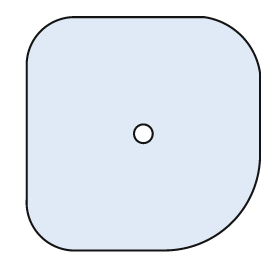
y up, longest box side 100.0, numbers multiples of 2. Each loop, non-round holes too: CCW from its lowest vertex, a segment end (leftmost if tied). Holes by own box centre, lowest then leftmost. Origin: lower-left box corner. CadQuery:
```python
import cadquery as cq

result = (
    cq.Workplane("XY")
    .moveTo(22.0, 0.0)
    .lineTo(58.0, 0.0)
    .threePointArc((88.0, 12.0), (100.0, 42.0))
    .lineTo(100.0, 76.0)
    .threePointArc((92.0, 92.0), (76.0, 100.0))
    .lineTo(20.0, 100.0)
    .threePointArc((6.0, 94.0), (0.0, 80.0))
    .lineTo(0.0, 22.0)
    .threePointArc((6.0, 6.0), (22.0, 0.0))
    .close()
    .moveTo(50.0, 50.0)
    .circle(4.0)
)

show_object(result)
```